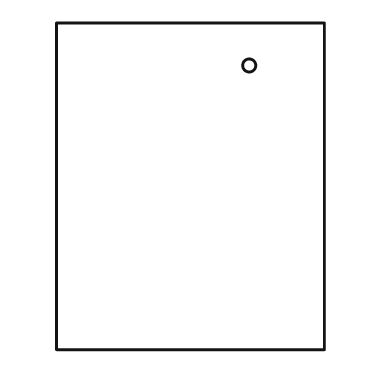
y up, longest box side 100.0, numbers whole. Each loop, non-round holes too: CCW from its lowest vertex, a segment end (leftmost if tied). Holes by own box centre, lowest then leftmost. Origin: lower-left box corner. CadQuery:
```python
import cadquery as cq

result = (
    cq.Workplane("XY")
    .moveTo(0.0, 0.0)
    .lineTo(82.0, 0.0)
    .lineTo(82.0, 100.0)
    .lineTo(0.0, 100.0)
    .close()
    .moveTo(59.0, 87.0)
    .circle(2.0)
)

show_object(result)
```